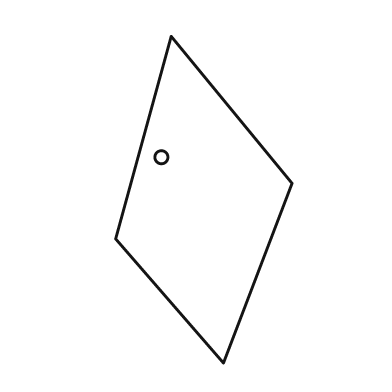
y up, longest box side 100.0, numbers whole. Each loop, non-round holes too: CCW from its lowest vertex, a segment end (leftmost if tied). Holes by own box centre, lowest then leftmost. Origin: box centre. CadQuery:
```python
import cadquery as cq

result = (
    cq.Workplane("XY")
    .moveTo(6.0, -50.0)
    .lineTo(27.0, 5.0)
    .lineTo(-10.0, 50.0)
    .lineTo(-27.0, -12.0)
    .close()
    .moveTo(-13.0, 13.0)
    .circle(2.0)
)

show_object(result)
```